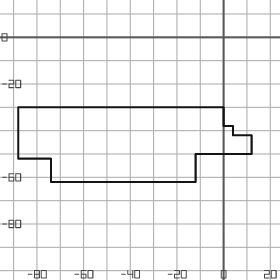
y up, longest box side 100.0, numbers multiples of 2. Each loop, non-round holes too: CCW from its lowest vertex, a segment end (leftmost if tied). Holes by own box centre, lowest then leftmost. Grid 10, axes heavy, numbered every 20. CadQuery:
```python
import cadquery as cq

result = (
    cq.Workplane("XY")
    .moveTo(-74.0, -62.0)
    .lineTo(-12.0, -62.0)
    .lineTo(-12.0, -50.0)
    .lineTo(12.0, -50.0)
    .lineTo(12.0, -42.0)
    .lineTo(4.0, -42.0)
    .lineTo(4.0, -38.0)
    .lineTo(0.0, -38.0)
    .lineTo(0.0, -30.0)
    .lineTo(-88.0, -30.0)
    .lineTo(-88.0, -52.0)
    .lineTo(-74.0, -52.0)
    .close()
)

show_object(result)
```